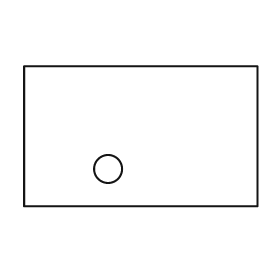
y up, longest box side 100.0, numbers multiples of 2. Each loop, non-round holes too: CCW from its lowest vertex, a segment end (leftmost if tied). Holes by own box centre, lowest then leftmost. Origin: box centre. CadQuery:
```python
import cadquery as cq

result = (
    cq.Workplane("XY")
    .moveTo(-50.0, -30.0)
    .lineTo(50.0, -30.0)
    .lineTo(50.0, 30.0)
    .lineTo(-50.0, 30.0)
    .close()
    .moveTo(-14.0, -14.0)
    .circle(6.0)
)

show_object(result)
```